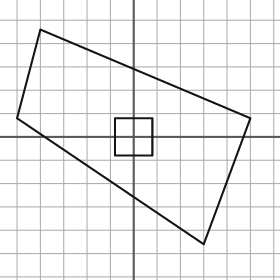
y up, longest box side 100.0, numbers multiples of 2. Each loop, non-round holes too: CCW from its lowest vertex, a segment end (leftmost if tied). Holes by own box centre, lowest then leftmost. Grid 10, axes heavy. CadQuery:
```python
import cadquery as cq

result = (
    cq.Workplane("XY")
    .moveTo(30.0, -46.0)
    .lineTo(50.0, 8.0)
    .lineTo(-40.0, 46.0)
    .lineTo(-50.0, 8.0)
    .close()
    .moveTo(-8.0, -8.0)
    .lineTo(8.0, -8.0)
    .lineTo(8.0, 8.0)
    .lineTo(-8.0, 8.0)
    .close()
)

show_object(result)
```